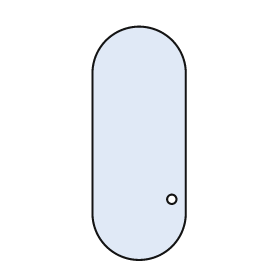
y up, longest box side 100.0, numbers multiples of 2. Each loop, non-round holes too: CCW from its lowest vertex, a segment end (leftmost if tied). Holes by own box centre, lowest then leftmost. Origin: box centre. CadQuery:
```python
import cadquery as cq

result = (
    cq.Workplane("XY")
    .moveTo(-20.0, -30.0)
    .threePointArc((0.0, -50.0), (20.0, -30.0))
    .lineTo(20.0, 30.0)
    .threePointArc((0.0, 50.0), (-20.0, 30.0))
    .close()
    .moveTo(14.0, -24.0)
    .circle(2.0)
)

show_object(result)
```